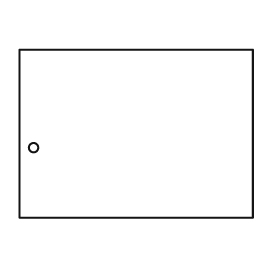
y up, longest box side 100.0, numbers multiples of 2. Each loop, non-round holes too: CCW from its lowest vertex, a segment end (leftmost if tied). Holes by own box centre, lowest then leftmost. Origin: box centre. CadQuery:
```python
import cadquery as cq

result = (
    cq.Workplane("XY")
    .moveTo(-50.0, -36.0)
    .lineTo(50.0, -36.0)
    .lineTo(50.0, 36.0)
    .lineTo(-50.0, 36.0)
    .close()
    .moveTo(-44.0, -6.0)
    .circle(2.0)
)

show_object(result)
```